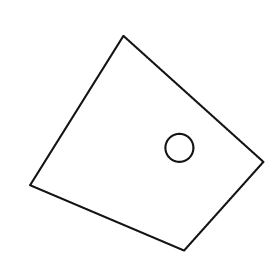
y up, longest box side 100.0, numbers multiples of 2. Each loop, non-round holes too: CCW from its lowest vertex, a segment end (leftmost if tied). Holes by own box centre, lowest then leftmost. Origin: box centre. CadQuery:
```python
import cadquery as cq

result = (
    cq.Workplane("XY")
    .moveTo(16.0, -46.0)
    .lineTo(50.0, -8.0)
    .lineTo(-10.0, 46.0)
    .lineTo(-50.0, -18.0)
    .close()
    .moveTo(14.0, -2.0)
    .circle(6.0)
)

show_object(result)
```